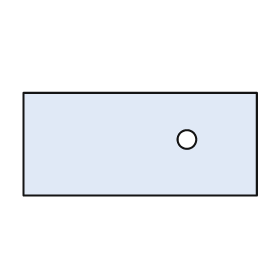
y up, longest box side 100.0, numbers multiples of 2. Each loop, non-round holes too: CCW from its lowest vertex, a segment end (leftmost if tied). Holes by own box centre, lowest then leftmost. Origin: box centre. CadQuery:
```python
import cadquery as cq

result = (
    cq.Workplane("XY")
    .moveTo(-50.0, -22.0)
    .lineTo(50.0, -22.0)
    .lineTo(50.0, 22.0)
    .lineTo(-50.0, 22.0)
    .close()
    .moveTo(20.0, 2.0)
    .circle(4.0)
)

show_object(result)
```